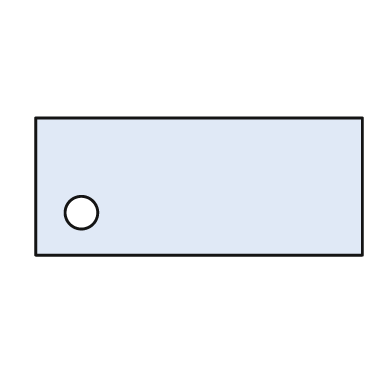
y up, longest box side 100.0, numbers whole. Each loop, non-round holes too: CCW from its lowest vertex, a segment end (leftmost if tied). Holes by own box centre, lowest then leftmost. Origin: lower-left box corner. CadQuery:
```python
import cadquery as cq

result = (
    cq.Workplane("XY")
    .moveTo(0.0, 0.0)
    .lineTo(100.0, 0.0)
    .lineTo(100.0, 42.0)
    .lineTo(0.0, 42.0)
    .close()
    .moveTo(14.0, 13.0)
    .circle(5.0)
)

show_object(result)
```